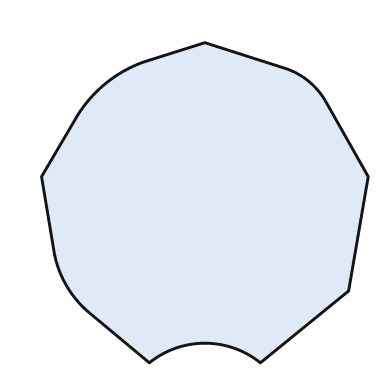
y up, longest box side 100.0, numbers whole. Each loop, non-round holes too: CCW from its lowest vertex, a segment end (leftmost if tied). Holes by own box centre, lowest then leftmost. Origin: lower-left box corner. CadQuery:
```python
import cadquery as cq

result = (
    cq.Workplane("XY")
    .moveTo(33.0, 0.0)
    .threePointArc((50.0, 6.0), (67.0, 0.0))
    .lineTo(94.0, 22.0)
    .lineTo(100.0, 57.0)
    .lineTo(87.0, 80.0)
    .threePointArc((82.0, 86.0), (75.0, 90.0))
    .lineTo(50.0, 98.0)
    .lineTo(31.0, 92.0)
    .threePointArc((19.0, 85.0), (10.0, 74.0))
    .lineTo(0.0, 57.0)
    .lineTo(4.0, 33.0)
    .threePointArc((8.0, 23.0), (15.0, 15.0))
    .close()
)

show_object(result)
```